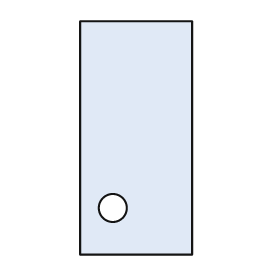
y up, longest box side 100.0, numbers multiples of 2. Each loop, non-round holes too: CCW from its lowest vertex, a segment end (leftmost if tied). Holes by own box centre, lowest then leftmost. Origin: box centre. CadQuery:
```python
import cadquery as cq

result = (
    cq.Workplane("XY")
    .moveTo(-24.0, -50.0)
    .lineTo(24.0, -50.0)
    .lineTo(24.0, 50.0)
    .lineTo(-24.0, 50.0)
    .close()
    .moveTo(-10.0, -30.0)
    .circle(6.0)
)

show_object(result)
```